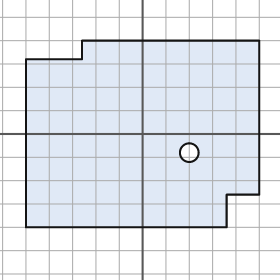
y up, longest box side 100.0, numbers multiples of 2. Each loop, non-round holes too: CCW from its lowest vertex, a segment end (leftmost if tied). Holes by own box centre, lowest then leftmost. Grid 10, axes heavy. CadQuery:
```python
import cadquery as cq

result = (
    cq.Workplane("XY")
    .moveTo(-50.0, -40.0)
    .lineTo(36.0, -40.0)
    .lineTo(36.0, -26.0)
    .lineTo(50.0, -26.0)
    .lineTo(50.0, 40.0)
    .lineTo(-26.0, 40.0)
    .lineTo(-26.0, 32.0)
    .lineTo(-50.0, 32.0)
    .close()
    .moveTo(20.0, -8.0)
    .circle(4.0)
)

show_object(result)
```